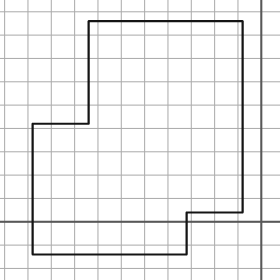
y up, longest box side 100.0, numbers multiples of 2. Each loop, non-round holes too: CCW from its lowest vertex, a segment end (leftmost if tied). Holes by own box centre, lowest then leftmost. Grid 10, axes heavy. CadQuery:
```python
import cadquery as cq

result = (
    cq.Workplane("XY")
    .moveTo(-98.0, -14.0)
    .lineTo(-32.0, -14.0)
    .lineTo(-32.0, 4.0)
    .lineTo(-8.0, 4.0)
    .lineTo(-8.0, 86.0)
    .lineTo(-74.0, 86.0)
    .lineTo(-74.0, 42.0)
    .lineTo(-98.0, 42.0)
    .close()
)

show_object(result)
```